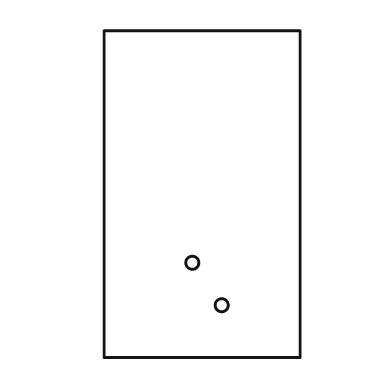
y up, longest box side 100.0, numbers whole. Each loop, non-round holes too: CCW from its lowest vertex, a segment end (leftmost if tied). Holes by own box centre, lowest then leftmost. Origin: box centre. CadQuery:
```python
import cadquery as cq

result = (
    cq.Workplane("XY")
    .moveTo(-30.0, -50.0)
    .lineTo(30.0, -50.0)
    .lineTo(30.0, 50.0)
    .lineTo(-30.0, 50.0)
    .close()
    .moveTo(6.0, -34.0)
    .circle(2.0)
    .moveTo(-3.0, -21.0)
    .circle(2.0)
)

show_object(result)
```